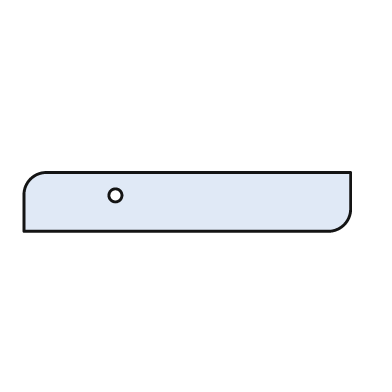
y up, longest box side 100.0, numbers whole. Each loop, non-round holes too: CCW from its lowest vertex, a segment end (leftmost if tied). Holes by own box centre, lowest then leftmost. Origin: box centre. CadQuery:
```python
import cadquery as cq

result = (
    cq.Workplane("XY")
    .moveTo(-50.0, -9.0)
    .lineTo(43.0, -9.0)
    .threePointArc((48.0, -7.0), (50.0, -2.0))
    .lineTo(50.0, 9.0)
    .lineTo(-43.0, 9.0)
    .threePointArc((-48.0, 7.0), (-50.0, 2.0))
    .close()
    .moveTo(-22.0, 2.0)
    .circle(2.0)
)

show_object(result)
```